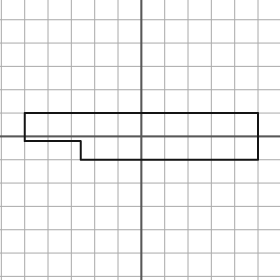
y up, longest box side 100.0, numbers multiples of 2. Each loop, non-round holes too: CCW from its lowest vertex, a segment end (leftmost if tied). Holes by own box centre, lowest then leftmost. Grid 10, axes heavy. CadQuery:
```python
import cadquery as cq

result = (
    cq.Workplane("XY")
    .moveTo(-26.0, -10.0)
    .lineTo(50.0, -10.0)
    .lineTo(50.0, 10.0)
    .lineTo(-50.0, 10.0)
    .lineTo(-50.0, -2.0)
    .lineTo(-26.0, -2.0)
    .close()
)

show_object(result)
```